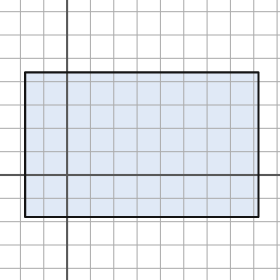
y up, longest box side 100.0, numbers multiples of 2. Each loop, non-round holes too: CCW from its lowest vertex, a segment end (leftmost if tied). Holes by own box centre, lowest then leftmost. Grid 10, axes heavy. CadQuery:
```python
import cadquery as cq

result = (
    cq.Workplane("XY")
    .moveTo(-18.0, -18.0)
    .lineTo(82.0, -18.0)
    .lineTo(82.0, 44.0)
    .lineTo(-18.0, 44.0)
    .close()
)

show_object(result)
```